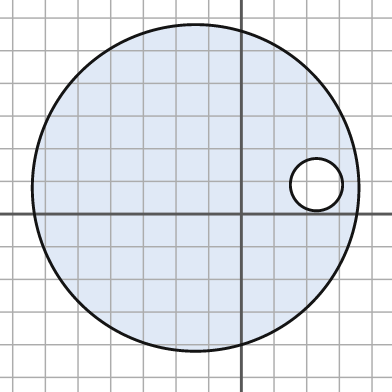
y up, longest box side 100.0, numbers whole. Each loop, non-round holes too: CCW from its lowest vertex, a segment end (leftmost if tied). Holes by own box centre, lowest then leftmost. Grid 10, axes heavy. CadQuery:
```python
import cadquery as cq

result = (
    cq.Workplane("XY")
    .moveTo(-14.0, 8.0)
    .circle(50.0)
    .moveTo(23.0, 9.0)
    .circle(8.0)
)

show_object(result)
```